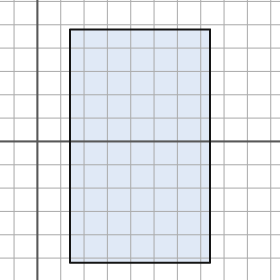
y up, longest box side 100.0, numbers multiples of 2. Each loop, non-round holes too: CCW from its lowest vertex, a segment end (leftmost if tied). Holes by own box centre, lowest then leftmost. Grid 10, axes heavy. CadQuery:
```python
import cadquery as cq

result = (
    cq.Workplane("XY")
    .moveTo(14.0, -52.0)
    .lineTo(74.0, -52.0)
    .lineTo(74.0, 48.0)
    .lineTo(14.0, 48.0)
    .close()
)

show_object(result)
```